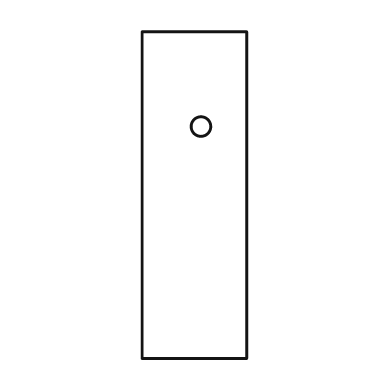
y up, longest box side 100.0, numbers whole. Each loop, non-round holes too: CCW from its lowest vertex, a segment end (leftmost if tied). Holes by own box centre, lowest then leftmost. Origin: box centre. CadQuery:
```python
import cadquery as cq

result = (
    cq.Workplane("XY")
    .moveTo(-16.0, -50.0)
    .lineTo(16.0, -50.0)
    .lineTo(16.0, 50.0)
    .lineTo(-16.0, 50.0)
    .close()
    .moveTo(2.0, 21.0)
    .circle(3.0)
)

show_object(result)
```